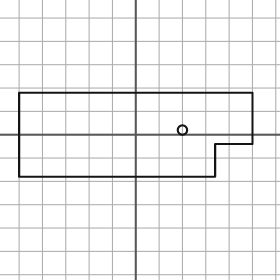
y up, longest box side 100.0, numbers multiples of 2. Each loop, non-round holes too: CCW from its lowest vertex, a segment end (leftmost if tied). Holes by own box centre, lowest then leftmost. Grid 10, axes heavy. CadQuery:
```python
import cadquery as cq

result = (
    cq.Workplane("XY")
    .moveTo(-50.0, -18.0)
    .lineTo(34.0, -18.0)
    .lineTo(34.0, -4.0)
    .lineTo(50.0, -4.0)
    .lineTo(50.0, 18.0)
    .lineTo(-50.0, 18.0)
    .close()
    .moveTo(20.0, 2.0)
    .circle(2.0)
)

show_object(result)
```